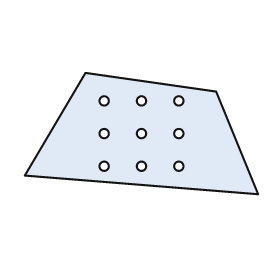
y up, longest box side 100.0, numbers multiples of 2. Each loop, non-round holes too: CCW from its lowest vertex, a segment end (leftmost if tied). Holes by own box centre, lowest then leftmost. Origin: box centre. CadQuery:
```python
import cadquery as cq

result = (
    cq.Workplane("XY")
    .moveTo(50.0, -26.0)
    .lineTo(32.0, 18.0)
    .lineTo(-24.0, 26.0)
    .lineTo(-50.0, -18.0)
    .close()
    .moveTo(-16.0, -14.0)
    .circle(2.0)
    .moveTo(0.0, -14.0)
    .circle(2.0)
    .moveTo(16.0, -14.0)
    .circle(2.0)
    .moveTo(-16.0, 0.0)
    .circle(2.0)
    .moveTo(0.0, 0.0)
    .circle(2.0)
    .moveTo(16.0, 0.0)
    .circle(2.0)
    .moveTo(-16.0, 14.0)
    .circle(2.0)
    .moveTo(0.0, 14.0)
    .circle(2.0)
    .moveTo(16.0, 14.0)
    .circle(2.0)
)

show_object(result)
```